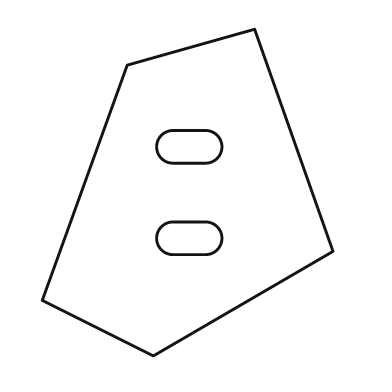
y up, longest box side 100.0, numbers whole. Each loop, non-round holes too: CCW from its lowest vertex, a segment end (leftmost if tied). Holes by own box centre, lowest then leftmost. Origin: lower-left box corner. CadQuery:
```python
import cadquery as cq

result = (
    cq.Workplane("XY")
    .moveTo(34.0, 0.0)
    .lineTo(89.0, 32.0)
    .lineTo(65.0, 100.0)
    .lineTo(26.0, 89.0)
    .lineTo(0.0, 17.0)
    .close()
    .moveTo(40.0, 31.0)
    .lineTo(50.0, 31.0)
    .threePointArc((55.0, 36.0), (50.0, 41.0))
    .lineTo(40.0, 41.0)
    .threePointArc((35.0, 36.0), (40.0, 31.0))
    .close()
    .moveTo(40.0, 59.0)
    .lineTo(50.0, 59.0)
    .threePointArc((55.0, 64.0), (50.0, 69.0))
    .lineTo(40.0, 69.0)
    .threePointArc((35.0, 64.0), (40.0, 59.0))
    .close()
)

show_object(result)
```